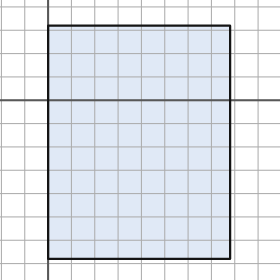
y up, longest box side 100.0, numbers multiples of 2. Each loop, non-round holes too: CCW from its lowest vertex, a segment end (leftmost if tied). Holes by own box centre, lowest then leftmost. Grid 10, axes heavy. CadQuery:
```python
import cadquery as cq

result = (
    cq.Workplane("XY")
    .moveTo(0.0, -68.0)
    .lineTo(78.0, -68.0)
    .lineTo(78.0, 32.0)
    .lineTo(0.0, 32.0)
    .close()
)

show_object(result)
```